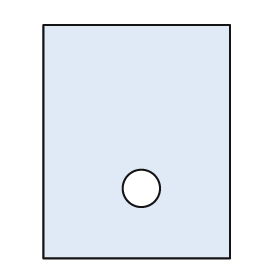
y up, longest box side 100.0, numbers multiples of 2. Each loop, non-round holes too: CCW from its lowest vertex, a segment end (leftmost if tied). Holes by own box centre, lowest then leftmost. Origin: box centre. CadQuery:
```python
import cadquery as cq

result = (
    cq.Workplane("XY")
    .moveTo(-40.0, -50.0)
    .lineTo(40.0, -50.0)
    .lineTo(40.0, 50.0)
    .lineTo(-40.0, 50.0)
    .close()
    .moveTo(2.0, -20.0)
    .circle(8.0)
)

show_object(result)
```